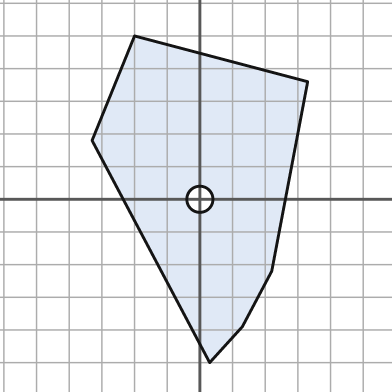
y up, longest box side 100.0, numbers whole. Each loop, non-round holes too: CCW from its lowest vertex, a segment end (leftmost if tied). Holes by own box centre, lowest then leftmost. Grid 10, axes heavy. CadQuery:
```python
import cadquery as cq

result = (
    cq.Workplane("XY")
    .moveTo(3.0, -50.0)
    .lineTo(13.0, -39.0)
    .lineTo(22.0, -22.0)
    .lineTo(33.0, 36.0)
    .lineTo(-20.0, 50.0)
    .lineTo(-33.0, 18.0)
    .close()
    .moveTo(0.0, 0.0)
    .circle(4.0)
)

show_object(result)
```